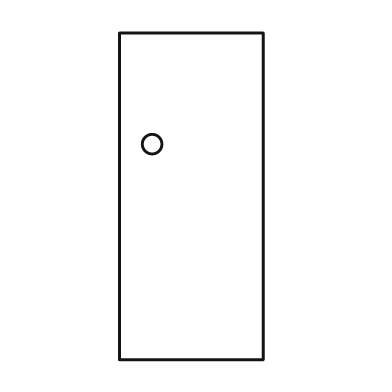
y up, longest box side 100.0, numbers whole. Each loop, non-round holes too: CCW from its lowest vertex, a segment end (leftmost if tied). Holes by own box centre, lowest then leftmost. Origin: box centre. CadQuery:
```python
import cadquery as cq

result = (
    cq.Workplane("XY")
    .moveTo(-22.0, -50.0)
    .lineTo(22.0, -50.0)
    .lineTo(22.0, 50.0)
    .lineTo(-22.0, 50.0)
    .close()
    .moveTo(-12.0, 16.0)
    .circle(3.0)
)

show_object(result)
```